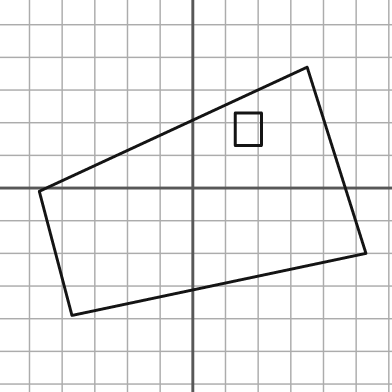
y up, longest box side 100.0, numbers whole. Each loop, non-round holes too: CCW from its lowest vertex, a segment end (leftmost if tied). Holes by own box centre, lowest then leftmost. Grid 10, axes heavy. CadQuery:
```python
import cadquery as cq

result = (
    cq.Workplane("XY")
    .moveTo(-37.0, -39.0)
    .lineTo(53.0, -20.0)
    .lineTo(35.0, 37.0)
    .lineTo(-47.0, -1.0)
    .close()
    .moveTo(13.0, 13.0)
    .lineTo(21.0, 13.0)
    .lineTo(21.0, 23.0)
    .lineTo(13.0, 23.0)
    .close()
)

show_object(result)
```